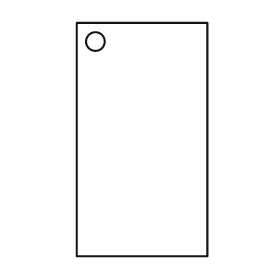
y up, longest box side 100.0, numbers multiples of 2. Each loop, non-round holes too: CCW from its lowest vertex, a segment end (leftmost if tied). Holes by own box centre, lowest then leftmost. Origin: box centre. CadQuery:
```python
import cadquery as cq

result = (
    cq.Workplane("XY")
    .moveTo(-28.0, -50.0)
    .lineTo(28.0, -50.0)
    .lineTo(28.0, 50.0)
    .lineTo(-28.0, 50.0)
    .close()
    .moveTo(-20.0, 42.0)
    .circle(4.0)
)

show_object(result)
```